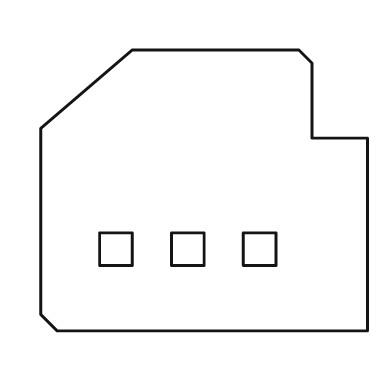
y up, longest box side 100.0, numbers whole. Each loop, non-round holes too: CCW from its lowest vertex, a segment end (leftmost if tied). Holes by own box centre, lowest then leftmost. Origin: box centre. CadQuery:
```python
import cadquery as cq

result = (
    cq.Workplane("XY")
    .moveTo(-45.0, -43.0)
    .lineTo(50.0, -43.0)
    .lineTo(50.0, 16.0)
    .lineTo(33.0, 16.0)
    .lineTo(33.0, 39.0)
    .lineTo(29.0, 43.0)
    .lineTo(-22.0, 43.0)
    .lineTo(-50.0, 19.0)
    .lineTo(-50.0, -38.0)
    .close()
    .moveTo(-32.0, -23.0)
    .lineTo(-22.0, -23.0)
    .lineTo(-22.0, -13.0)
    .lineTo(-32.0, -13.0)
    .close()
    .moveTo(-10.0, -23.0)
    .lineTo(0.0, -23.0)
    .lineTo(0.0, -13.0)
    .lineTo(-10.0, -13.0)
    .close()
    .moveTo(12.0, -23.0)
    .lineTo(22.0, -23.0)
    .lineTo(22.0, -13.0)
    .lineTo(12.0, -13.0)
    .close()
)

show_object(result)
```